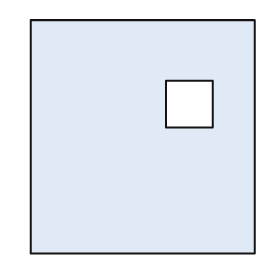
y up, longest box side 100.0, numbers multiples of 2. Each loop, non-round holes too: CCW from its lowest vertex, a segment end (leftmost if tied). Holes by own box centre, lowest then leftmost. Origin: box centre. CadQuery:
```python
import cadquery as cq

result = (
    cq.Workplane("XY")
    .moveTo(-48.0, -50.0)
    .lineTo(48.0, -50.0)
    .lineTo(48.0, 50.0)
    .lineTo(-48.0, 50.0)
    .close()
    .moveTo(10.0, 4.0)
    .lineTo(30.0, 4.0)
    .lineTo(30.0, 24.0)
    .lineTo(10.0, 24.0)
    .close()
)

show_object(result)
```